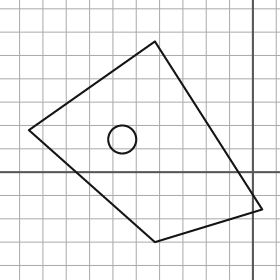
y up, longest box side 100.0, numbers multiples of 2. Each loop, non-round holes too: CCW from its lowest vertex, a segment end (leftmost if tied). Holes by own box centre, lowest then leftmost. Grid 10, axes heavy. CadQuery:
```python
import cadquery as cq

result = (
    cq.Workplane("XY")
    .moveTo(-42.0, -30.0)
    .lineTo(4.0, -16.0)
    .lineTo(-42.0, 56.0)
    .lineTo(-96.0, 18.0)
    .close()
    .moveTo(-56.0, 14.0)
    .circle(6.0)
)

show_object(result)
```